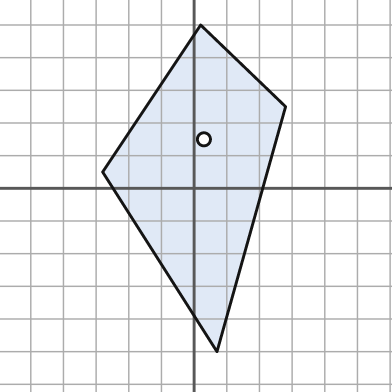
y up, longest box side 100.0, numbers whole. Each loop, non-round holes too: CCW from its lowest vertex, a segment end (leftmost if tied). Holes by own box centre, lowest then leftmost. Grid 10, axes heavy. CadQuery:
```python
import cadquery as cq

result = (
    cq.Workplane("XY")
    .moveTo(7.0, -50.0)
    .lineTo(28.0, 25.0)
    .lineTo(2.0, 50.0)
    .lineTo(-28.0, 5.0)
    .close()
    .moveTo(3.0, 15.0)
    .circle(2.0)
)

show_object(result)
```